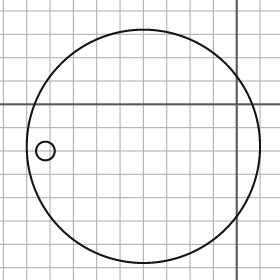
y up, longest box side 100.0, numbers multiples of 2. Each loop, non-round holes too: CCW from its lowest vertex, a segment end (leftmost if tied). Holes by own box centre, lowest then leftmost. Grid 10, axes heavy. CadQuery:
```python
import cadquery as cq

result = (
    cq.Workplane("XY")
    .moveTo(-40.0, -18.0)
    .circle(50.0)
    .moveTo(-82.0, -20.0)
    .circle(4.0)
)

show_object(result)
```